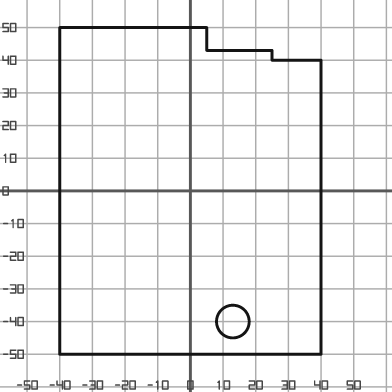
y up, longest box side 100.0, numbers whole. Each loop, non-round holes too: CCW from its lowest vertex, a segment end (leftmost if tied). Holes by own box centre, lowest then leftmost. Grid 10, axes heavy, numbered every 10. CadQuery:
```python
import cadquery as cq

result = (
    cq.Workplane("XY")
    .moveTo(-40.0, -50.0)
    .lineTo(40.0, -50.0)
    .lineTo(40.0, 40.0)
    .lineTo(25.0, 40.0)
    .lineTo(25.0, 43.0)
    .lineTo(5.0, 43.0)
    .lineTo(5.0, 50.0)
    .lineTo(-40.0, 50.0)
    .close()
    .moveTo(13.0, -40.0)
    .circle(5.0)
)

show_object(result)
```